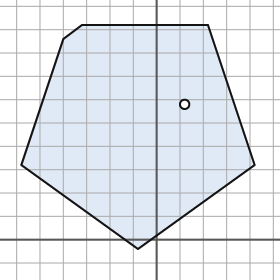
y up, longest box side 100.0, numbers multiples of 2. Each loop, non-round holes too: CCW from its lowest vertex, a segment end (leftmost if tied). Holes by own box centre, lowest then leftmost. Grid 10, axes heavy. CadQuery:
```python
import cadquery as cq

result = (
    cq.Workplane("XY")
    .moveTo(-8.0, -4.0)
    .lineTo(42.0, 32.0)
    .lineTo(22.0, 92.0)
    .lineTo(-32.0, 92.0)
    .lineTo(-40.0, 86.0)
    .lineTo(-58.0, 32.0)
    .close()
    .moveTo(12.0, 58.0)
    .circle(2.0)
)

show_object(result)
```